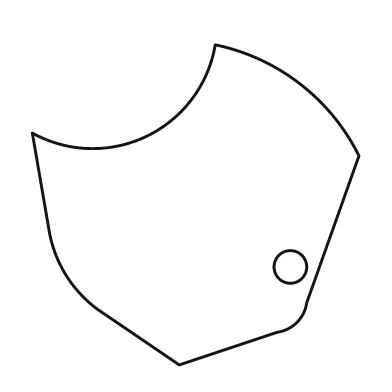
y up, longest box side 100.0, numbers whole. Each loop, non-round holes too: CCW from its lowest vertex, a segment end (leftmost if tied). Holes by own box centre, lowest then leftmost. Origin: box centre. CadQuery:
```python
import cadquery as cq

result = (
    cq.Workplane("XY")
    .moveTo(-5.0, -49.0)
    .lineTo(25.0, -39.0)
    .threePointArc((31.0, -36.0), (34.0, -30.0))
    .lineTo(50.0, 15.0)
    .threePointArc((32.0, 37.0), (6.0, 49.0))
    .threePointArc((-15.0, 21.0), (-50.0, 22.0))
    .lineTo(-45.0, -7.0)
    .threePointArc((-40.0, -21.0), (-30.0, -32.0))
    .close()
    .moveTo(29.0, -19.0)
    .circle(5.0)
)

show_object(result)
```